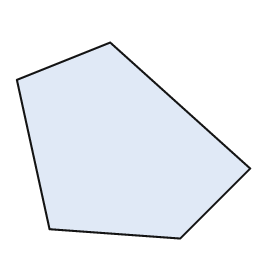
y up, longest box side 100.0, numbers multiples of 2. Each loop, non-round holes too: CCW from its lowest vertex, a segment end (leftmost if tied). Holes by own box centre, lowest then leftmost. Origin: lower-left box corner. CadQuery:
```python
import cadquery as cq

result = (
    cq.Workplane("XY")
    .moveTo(70.0, 0.0)
    .lineTo(100.0, 30.0)
    .lineTo(40.0, 84.0)
    .lineTo(0.0, 68.0)
    .lineTo(14.0, 4.0)
    .close()
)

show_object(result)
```